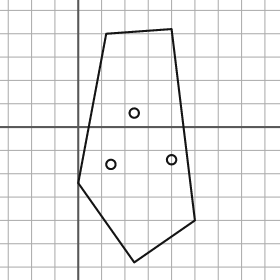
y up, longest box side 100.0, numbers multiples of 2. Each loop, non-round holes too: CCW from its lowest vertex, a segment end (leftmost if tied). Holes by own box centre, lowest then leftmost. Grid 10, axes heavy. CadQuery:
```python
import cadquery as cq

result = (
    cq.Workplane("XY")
    .moveTo(24.0, -58.0)
    .lineTo(50.0, -40.0)
    .lineTo(40.0, 42.0)
    .lineTo(12.0, 40.0)
    .lineTo(0.0, -24.0)
    .close()
    .moveTo(14.0, -16.0)
    .circle(2.0)
    .moveTo(40.0, -14.0)
    .circle(2.0)
    .moveTo(24.0, 6.0)
    .circle(2.0)
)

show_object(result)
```